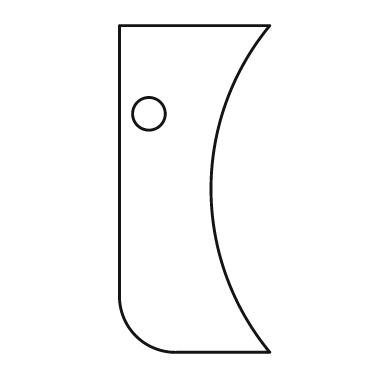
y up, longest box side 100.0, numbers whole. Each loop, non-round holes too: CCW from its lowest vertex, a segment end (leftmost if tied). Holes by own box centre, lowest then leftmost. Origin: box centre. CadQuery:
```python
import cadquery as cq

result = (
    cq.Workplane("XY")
    .moveTo(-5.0, -50.0)
    .lineTo(23.0, -50.0)
    .threePointArc((5.0, 0.0), (23.0, 50.0))
    .lineTo(-23.0, 50.0)
    .lineTo(-23.0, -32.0)
    .threePointArc((-18.0, -45.0), (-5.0, -50.0))
    .close()
    .moveTo(-14.0, 23.0)
    .circle(5.0)
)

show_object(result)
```